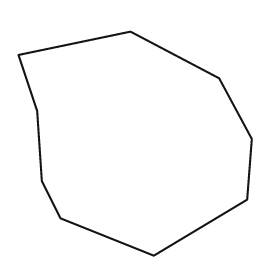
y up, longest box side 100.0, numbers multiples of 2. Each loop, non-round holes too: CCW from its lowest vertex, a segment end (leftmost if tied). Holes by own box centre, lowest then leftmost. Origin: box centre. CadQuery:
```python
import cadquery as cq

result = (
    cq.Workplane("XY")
    .moveTo(8.0, -48.0)
    .lineTo(48.0, -24.0)
    .lineTo(50.0, 2.0)
    .lineTo(36.0, 28.0)
    .lineTo(-2.0, 48.0)
    .lineTo(-50.0, 38.0)
    .lineTo(-42.0, 14.0)
    .lineTo(-40.0, -16.0)
    .lineTo(-32.0, -32.0)
    .close()
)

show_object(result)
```